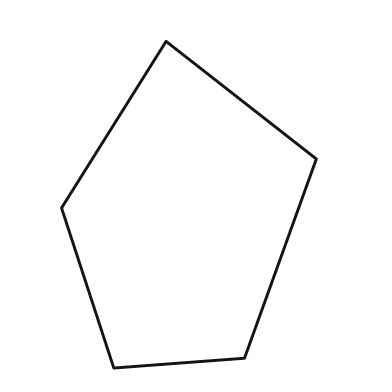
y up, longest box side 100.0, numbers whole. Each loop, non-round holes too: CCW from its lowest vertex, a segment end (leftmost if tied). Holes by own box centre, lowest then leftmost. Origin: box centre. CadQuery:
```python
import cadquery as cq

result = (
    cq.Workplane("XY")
    .moveTo(-23.0, -50.0)
    .lineTo(17.0, -47.0)
    .lineTo(39.0, 14.0)
    .lineTo(-7.0, 50.0)
    .lineTo(-39.0, -1.0)
    .close()
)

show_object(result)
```